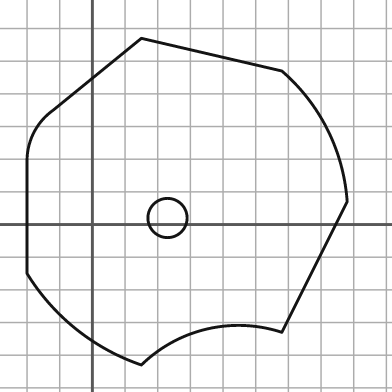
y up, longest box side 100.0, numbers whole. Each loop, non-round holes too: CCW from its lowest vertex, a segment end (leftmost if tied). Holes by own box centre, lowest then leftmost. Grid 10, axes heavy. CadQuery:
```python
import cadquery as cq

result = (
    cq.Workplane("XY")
    .moveTo(15.0, -43.0)
    .threePointArc((35.0, -32.0), (58.0, -33.0))
    .lineTo(78.0, 7.0)
    .threePointArc((72.0, 29.0), (58.0, 47.0))
    .lineTo(15.0, 57.0)
    .lineTo(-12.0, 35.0)
    .threePointArc((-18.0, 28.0), (-20.0, 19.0))
    .lineTo(-20.0, -15.0)
    .threePointArc((-5.0, -32.0), (15.0, -43.0))
    .close()
    .moveTo(23.0, 2.0)
    .circle(6.0)
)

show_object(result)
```